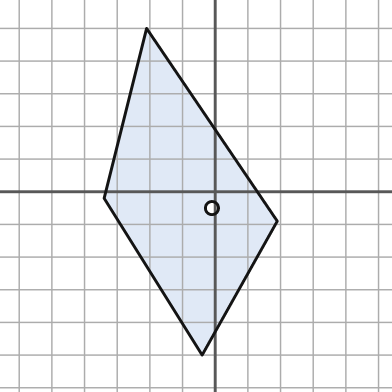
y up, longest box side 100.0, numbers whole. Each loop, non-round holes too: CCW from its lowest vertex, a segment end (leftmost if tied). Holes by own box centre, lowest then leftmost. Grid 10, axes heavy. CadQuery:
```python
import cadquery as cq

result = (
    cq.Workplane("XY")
    .moveTo(-4.0, -50.0)
    .lineTo(19.0, -9.0)
    .lineTo(-21.0, 50.0)
    .lineTo(-34.0, -2.0)
    .close()
    .moveTo(-1.0, -5.0)
    .circle(2.0)
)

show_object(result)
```